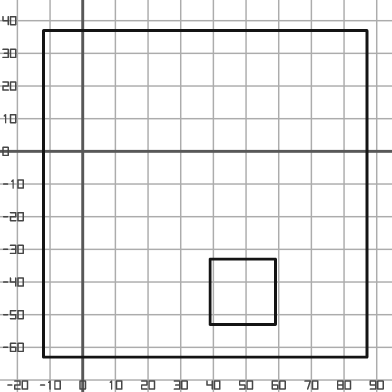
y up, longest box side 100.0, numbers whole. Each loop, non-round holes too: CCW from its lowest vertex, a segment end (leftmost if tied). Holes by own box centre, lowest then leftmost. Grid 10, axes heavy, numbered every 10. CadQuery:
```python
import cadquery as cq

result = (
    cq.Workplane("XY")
    .moveTo(-12.0, -63.0)
    .lineTo(87.0, -63.0)
    .lineTo(87.0, 37.0)
    .lineTo(-12.0, 37.0)
    .close()
    .moveTo(39.0, -53.0)
    .lineTo(59.0, -53.0)
    .lineTo(59.0, -33.0)
    .lineTo(39.0, -33.0)
    .close()
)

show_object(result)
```